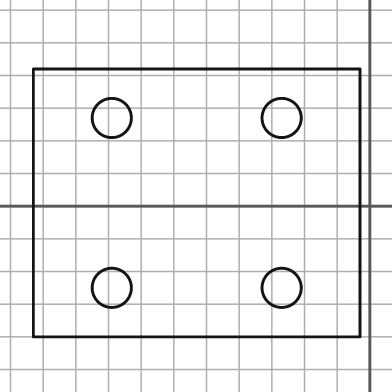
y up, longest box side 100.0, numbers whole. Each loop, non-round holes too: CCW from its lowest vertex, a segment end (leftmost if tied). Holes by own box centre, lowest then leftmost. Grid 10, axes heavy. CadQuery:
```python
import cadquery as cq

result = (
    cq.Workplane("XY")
    .moveTo(-103.0, -40.0)
    .lineTo(-3.0, -40.0)
    .lineTo(-3.0, 42.0)
    .lineTo(-103.0, 42.0)
    .close()
    .moveTo(-79.0, -25.0)
    .circle(6.0)
    .moveTo(-27.0, -25.0)
    .circle(6.0)
    .moveTo(-79.0, 27.0)
    .circle(6.0)
    .moveTo(-27.0, 27.0)
    .circle(6.0)
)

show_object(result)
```